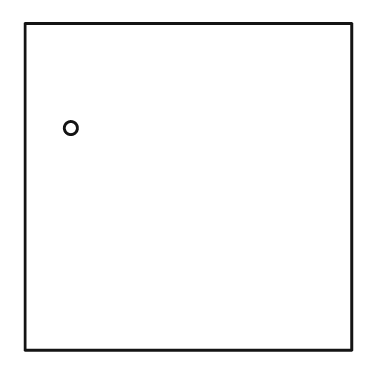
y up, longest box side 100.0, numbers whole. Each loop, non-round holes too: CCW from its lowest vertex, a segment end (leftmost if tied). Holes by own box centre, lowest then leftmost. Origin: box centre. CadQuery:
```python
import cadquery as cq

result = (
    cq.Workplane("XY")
    .moveTo(-50.0, -50.0)
    .lineTo(50.0, -50.0)
    .lineTo(50.0, 50.0)
    .lineTo(-50.0, 50.0)
    .close()
    .moveTo(-36.0, 18.0)
    .circle(2.0)
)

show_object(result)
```